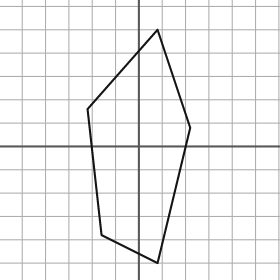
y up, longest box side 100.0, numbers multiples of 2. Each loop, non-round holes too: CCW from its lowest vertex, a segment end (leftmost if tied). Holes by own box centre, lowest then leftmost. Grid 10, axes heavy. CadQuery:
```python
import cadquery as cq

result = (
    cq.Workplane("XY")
    .moveTo(8.0, -50.0)
    .lineTo(22.0, 8.0)
    .lineTo(8.0, 50.0)
    .lineTo(-22.0, 16.0)
    .lineTo(-16.0, -38.0)
    .close()
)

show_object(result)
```